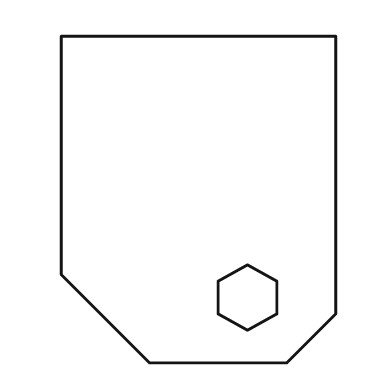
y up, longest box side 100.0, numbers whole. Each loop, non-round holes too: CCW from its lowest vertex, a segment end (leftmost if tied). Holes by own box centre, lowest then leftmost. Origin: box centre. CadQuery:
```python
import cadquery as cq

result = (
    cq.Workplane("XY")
    .moveTo(-15.0, -50.0)
    .lineTo(27.0, -50.0)
    .lineTo(42.0, -35.0)
    .lineTo(42.0, 50.0)
    .lineTo(-42.0, 50.0)
    .lineTo(-42.0, -23.0)
    .close()
    .moveTo(15.0, -40.0)
    .lineTo(24.0, -35.0)
    .lineTo(24.0, -25.0)
    .lineTo(15.0, -20.0)
    .lineTo(6.0, -25.0)
    .lineTo(6.0, -35.0)
    .close()
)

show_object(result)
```